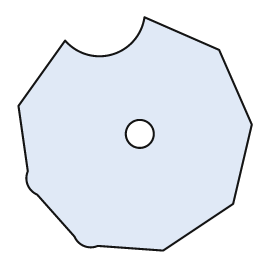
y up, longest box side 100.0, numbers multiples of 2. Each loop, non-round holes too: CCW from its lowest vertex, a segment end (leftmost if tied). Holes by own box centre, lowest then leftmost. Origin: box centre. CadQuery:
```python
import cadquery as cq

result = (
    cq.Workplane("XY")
    .moveTo(12.0, -50.0)
    .lineTo(42.0, -30.0)
    .lineTo(50.0, 4.0)
    .lineTo(36.0, 36.0)
    .lineTo(4.0, 50.0)
    .threePointArc((-10.0, 34.0), (-30.0, 40.0))
    .lineTo(-50.0, 12.0)
    .lineTo(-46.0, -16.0)
    .threePointArc((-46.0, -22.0), (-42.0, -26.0))
    .lineTo(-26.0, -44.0)
    .threePointArc((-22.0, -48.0), (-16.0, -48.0))
    .close()
    .moveTo(2.0, 0.0)
    .circle(6.0)
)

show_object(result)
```